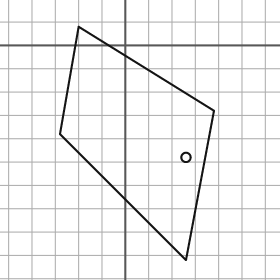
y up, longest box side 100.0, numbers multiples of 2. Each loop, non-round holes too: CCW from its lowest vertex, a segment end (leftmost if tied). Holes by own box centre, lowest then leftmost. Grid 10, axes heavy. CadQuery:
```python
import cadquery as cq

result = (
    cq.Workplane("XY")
    .moveTo(26.0, -92.0)
    .lineTo(38.0, -28.0)
    .lineTo(-20.0, 8.0)
    .lineTo(-28.0, -38.0)
    .close()
    .moveTo(26.0, -48.0)
    .circle(2.0)
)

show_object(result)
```